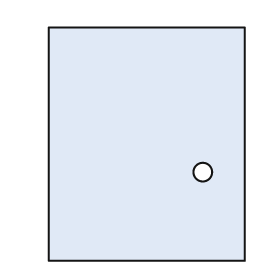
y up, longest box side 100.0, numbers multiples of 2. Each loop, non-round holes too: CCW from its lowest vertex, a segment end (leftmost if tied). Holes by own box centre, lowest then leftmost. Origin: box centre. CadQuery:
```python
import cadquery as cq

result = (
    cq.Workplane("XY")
    .moveTo(-42.0, -50.0)
    .lineTo(42.0, -50.0)
    .lineTo(42.0, 50.0)
    .lineTo(-42.0, 50.0)
    .close()
    .moveTo(24.0, -12.0)
    .circle(4.0)
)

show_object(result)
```